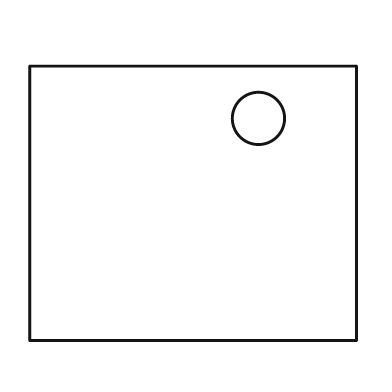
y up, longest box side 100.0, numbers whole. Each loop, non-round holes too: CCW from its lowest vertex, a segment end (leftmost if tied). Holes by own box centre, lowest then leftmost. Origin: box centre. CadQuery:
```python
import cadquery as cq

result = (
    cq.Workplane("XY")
    .moveTo(-50.0, -42.0)
    .lineTo(50.0, -42.0)
    .lineTo(50.0, 42.0)
    .lineTo(-50.0, 42.0)
    .close()
    .moveTo(20.0, 26.0)
    .circle(8.0)
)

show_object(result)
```